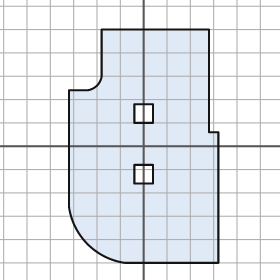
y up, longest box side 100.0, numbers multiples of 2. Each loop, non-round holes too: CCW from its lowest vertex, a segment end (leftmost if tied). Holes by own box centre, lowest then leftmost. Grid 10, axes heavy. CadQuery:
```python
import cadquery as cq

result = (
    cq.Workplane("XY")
    .moveTo(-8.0, -50.0)
    .lineTo(32.0, -50.0)
    .lineTo(32.0, 6.0)
    .lineTo(28.0, 6.0)
    .lineTo(28.0, 50.0)
    .lineTo(-18.0, 50.0)
    .lineTo(-18.0, 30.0)
    .threePointArc((-20.0, 26.0), (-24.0, 24.0))
    .lineTo(-32.0, 24.0)
    .lineTo(-32.0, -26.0)
    .threePointArc((-24.0, -42.0), (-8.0, -50.0))
    .close()
    .moveTo(-4.0, -16.0)
    .lineTo(4.0, -16.0)
    .lineTo(4.0, -8.0)
    .lineTo(-4.0, -8.0)
    .close()
    .moveTo(-4.0, 10.0)
    .lineTo(4.0, 10.0)
    .lineTo(4.0, 18.0)
    .lineTo(-4.0, 18.0)
    .close()
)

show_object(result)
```